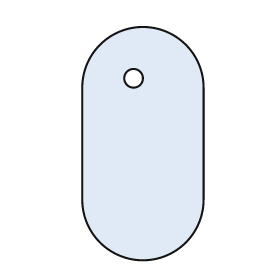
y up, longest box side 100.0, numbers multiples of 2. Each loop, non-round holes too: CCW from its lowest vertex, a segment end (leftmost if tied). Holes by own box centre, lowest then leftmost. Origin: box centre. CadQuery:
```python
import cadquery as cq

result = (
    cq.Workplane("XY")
    .moveTo(-26.0, -24.0)
    .threePointArc((0.0, -50.0), (26.0, -24.0))
    .lineTo(26.0, 24.0)
    .threePointArc((0.0, 50.0), (-26.0, 24.0))
    .close()
    .moveTo(-4.0, 28.0)
    .circle(4.0)
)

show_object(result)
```